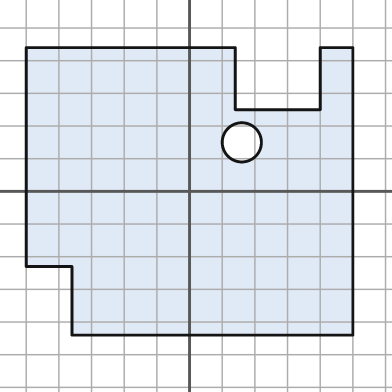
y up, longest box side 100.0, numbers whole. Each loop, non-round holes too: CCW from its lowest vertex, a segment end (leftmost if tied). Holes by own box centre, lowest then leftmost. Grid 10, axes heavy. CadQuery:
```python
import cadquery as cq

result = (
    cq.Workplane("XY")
    .moveTo(-36.0, -44.0)
    .lineTo(50.0, -44.0)
    .lineTo(50.0, 44.0)
    .lineTo(40.0, 44.0)
    .lineTo(40.0, 25.0)
    .lineTo(14.0, 25.0)
    .lineTo(14.0, 44.0)
    .lineTo(-50.0, 44.0)
    .lineTo(-50.0, -23.0)
    .lineTo(-36.0, -23.0)
    .close()
    .moveTo(16.0, 15.0)
    .circle(6.0)
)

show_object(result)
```